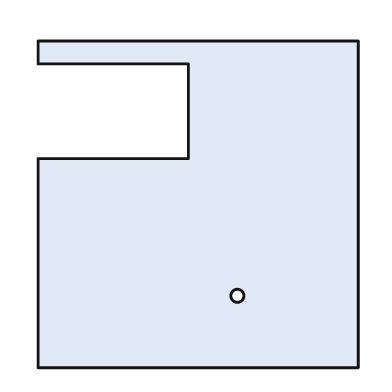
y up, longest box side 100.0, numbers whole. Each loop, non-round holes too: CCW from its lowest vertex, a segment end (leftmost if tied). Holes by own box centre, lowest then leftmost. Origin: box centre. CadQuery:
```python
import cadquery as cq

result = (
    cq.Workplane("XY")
    .moveTo(-49.0, -50.0)
    .lineTo(49.0, -50.0)
    .lineTo(49.0, 50.0)
    .lineTo(-49.0, 50.0)
    .lineTo(-49.0, 43.0)
    .lineTo(-3.0, 43.0)
    .lineTo(-3.0, 14.0)
    .lineTo(-49.0, 14.0)
    .close()
    .moveTo(12.0, -28.0)
    .circle(2.0)
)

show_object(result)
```